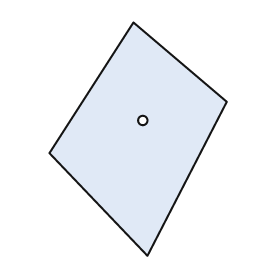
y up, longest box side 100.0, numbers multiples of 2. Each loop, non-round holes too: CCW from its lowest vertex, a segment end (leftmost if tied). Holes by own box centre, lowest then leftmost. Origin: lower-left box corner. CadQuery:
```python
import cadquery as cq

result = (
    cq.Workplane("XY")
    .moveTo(42.0, 0.0)
    .lineTo(76.0, 66.0)
    .lineTo(36.0, 100.0)
    .lineTo(0.0, 44.0)
    .close()
    .moveTo(40.0, 58.0)
    .circle(2.0)
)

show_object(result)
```